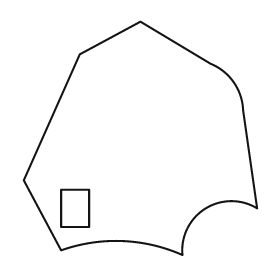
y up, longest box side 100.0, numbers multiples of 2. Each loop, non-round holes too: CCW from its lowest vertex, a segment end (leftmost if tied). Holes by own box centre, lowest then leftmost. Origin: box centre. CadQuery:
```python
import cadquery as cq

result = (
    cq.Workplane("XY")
    .moveTo(18.0, -50.0)
    .threePointArc((28.0, -30.0), (50.0, -30.0))
    .lineTo(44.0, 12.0)
    .threePointArc((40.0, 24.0), (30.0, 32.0))
    .lineTo(0.0, 50.0)
    .lineTo(-26.0, 36.0)
    .lineTo(-50.0, -18.0)
    .lineTo(-34.0, -48.0)
    .threePointArc((-8.0, -44.0), (18.0, -50.0))
    .close()
    .moveTo(-34.0, -38.0)
    .lineTo(-22.0, -38.0)
    .lineTo(-22.0, -22.0)
    .lineTo(-34.0, -22.0)
    .close()
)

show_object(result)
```